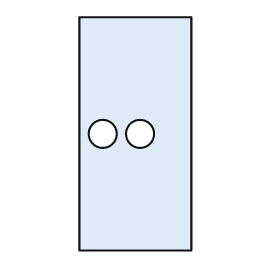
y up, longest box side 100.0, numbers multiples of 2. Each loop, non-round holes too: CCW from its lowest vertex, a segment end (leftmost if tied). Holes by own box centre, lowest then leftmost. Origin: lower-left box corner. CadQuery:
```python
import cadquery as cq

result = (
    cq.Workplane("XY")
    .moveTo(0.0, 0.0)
    .lineTo(48.0, 0.0)
    .lineTo(48.0, 100.0)
    .lineTo(0.0, 100.0)
    .close()
    .moveTo(10.0, 50.0)
    .circle(6.0)
    .moveTo(26.0, 50.0)
    .circle(6.0)
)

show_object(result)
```